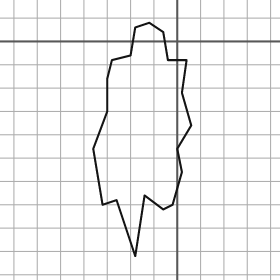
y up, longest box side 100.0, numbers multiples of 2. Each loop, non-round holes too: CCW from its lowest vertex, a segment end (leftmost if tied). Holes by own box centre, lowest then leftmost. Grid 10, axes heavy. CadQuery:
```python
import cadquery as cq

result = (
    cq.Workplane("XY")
    .moveTo(-18.0, -92.0)
    .lineTo(-14.0, -66.0)
    .lineTo(-6.0, -72.0)
    .lineTo(-2.0, -70.0)
    .lineTo(2.0, -56.0)
    .lineTo(0.0, -46.0)
    .lineTo(6.0, -36.0)
    .lineTo(2.0, -22.0)
    .lineTo(4.0, -8.0)
    .lineTo(-4.0, -8.0)
    .lineTo(-6.0, 4.0)
    .lineTo(-12.0, 8.0)
    .lineTo(-18.0, 6.0)
    .lineTo(-20.0, -6.0)
    .lineTo(-28.0, -8.0)
    .lineTo(-30.0, -16.0)
    .lineTo(-30.0, -30.0)
    .lineTo(-36.0, -46.0)
    .lineTo(-32.0, -70.0)
    .lineTo(-26.0, -68.0)
    .close()
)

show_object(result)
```